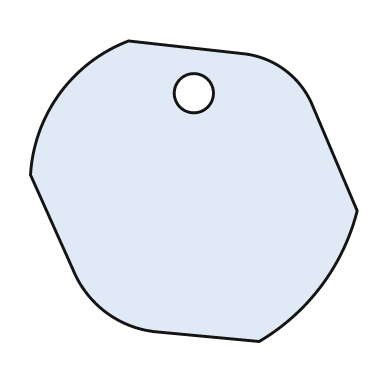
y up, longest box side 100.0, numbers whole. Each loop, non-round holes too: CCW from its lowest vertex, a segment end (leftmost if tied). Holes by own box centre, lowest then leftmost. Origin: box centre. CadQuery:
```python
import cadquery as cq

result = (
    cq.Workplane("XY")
    .moveTo(20.0, -46.0)
    .threePointArc((39.0, -29.0), (50.0, -6.0))
    .lineTo(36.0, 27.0)
    .threePointArc((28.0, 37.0), (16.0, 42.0))
    .lineTo(-20.0, 46.0)
    .threePointArc((-41.0, 30.0), (-50.0, 5.0))
    .lineTo(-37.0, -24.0)
    .threePointArc((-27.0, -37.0), (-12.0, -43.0))
    .close()
    .moveTo(0.0, 30.0)
    .circle(6.0)
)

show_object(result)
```